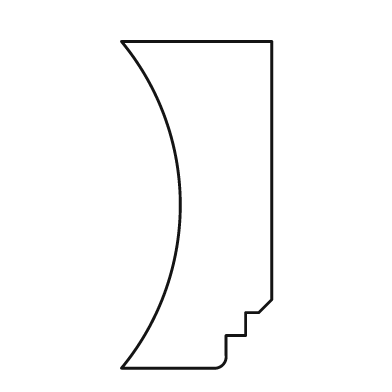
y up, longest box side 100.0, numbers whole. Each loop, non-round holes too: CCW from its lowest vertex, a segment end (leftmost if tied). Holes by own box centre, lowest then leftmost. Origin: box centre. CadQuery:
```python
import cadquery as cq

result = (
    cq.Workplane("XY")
    .moveTo(-23.0, -50.0)
    .lineTo(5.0, -50.0)
    .threePointArc((8.0, -49.0), (9.0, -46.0))
    .lineTo(9.0, -40.0)
    .lineTo(15.0, -40.0)
    .lineTo(15.0, -33.0)
    .lineTo(19.0, -33.0)
    .lineTo(23.0, -29.0)
    .lineTo(23.0, 50.0)
    .lineTo(-23.0, 50.0)
    .threePointArc((-5.0, 0.0), (-23.0, -50.0))
    .close()
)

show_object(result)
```